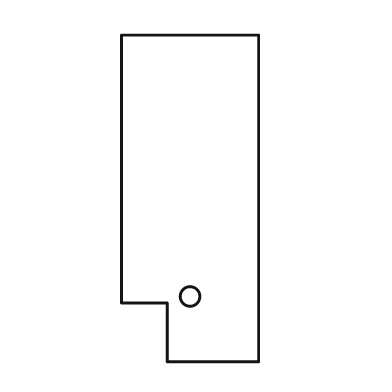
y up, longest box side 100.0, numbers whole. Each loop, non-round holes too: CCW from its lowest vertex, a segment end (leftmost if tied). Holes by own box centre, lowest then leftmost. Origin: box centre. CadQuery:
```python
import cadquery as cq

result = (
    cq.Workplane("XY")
    .moveTo(-7.0, -50.0)
    .lineTo(21.0, -50.0)
    .lineTo(21.0, 50.0)
    .lineTo(-21.0, 50.0)
    .lineTo(-21.0, -32.0)
    .lineTo(-7.0, -32.0)
    .close()
    .moveTo(0.0, -30.0)
    .circle(3.0)
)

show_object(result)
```